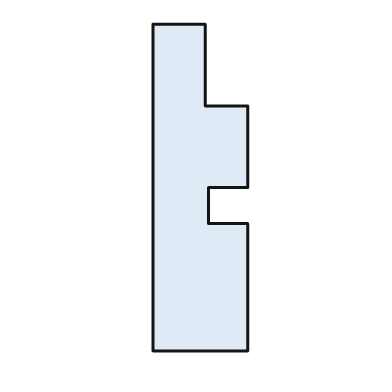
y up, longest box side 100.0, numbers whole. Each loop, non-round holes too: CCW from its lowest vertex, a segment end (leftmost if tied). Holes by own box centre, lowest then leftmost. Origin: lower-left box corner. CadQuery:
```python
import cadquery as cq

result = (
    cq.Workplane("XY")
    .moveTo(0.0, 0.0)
    .lineTo(29.0, 0.0)
    .lineTo(29.0, 39.0)
    .lineTo(17.0, 39.0)
    .lineTo(17.0, 50.0)
    .lineTo(29.0, 50.0)
    .lineTo(29.0, 75.0)
    .lineTo(16.0, 75.0)
    .lineTo(16.0, 100.0)
    .lineTo(0.0, 100.0)
    .close()
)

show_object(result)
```